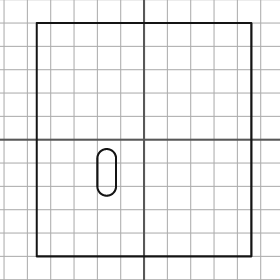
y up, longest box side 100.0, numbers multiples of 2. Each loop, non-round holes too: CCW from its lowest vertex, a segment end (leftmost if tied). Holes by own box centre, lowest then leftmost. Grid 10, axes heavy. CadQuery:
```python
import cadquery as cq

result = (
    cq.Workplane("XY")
    .moveTo(-46.0, -50.0)
    .lineTo(46.0, -50.0)
    .lineTo(46.0, 50.0)
    .lineTo(-46.0, 50.0)
    .close()
    .moveTo(-20.0, -20.0)
    .threePointArc((-16.0, -24.0), (-12.0, -20.0))
    .lineTo(-12.0, -8.0)
    .threePointArc((-16.0, -4.0), (-20.0, -8.0))
    .close()
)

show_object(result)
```